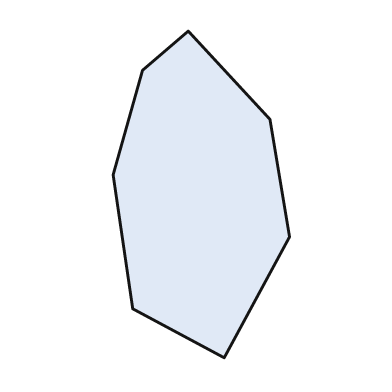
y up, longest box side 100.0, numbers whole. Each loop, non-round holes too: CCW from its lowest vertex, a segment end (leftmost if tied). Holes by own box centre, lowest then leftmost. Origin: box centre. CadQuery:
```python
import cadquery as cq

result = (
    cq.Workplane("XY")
    .moveTo(7.0, -50.0)
    .lineTo(27.0, -13.0)
    .lineTo(21.0, 23.0)
    .lineTo(-4.0, 50.0)
    .lineTo(-18.0, 38.0)
    .lineTo(-27.0, 6.0)
    .lineTo(-21.0, -35.0)
    .close()
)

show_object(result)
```